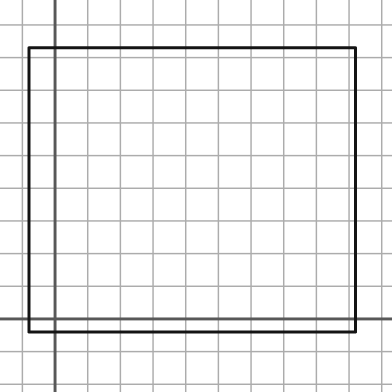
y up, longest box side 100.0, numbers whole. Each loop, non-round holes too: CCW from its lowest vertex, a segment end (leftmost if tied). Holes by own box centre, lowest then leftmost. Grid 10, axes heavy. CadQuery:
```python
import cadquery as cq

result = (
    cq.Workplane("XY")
    .moveTo(-8.0, -4.0)
    .lineTo(92.0, -4.0)
    .lineTo(92.0, 83.0)
    .lineTo(-8.0, 83.0)
    .close()
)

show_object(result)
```